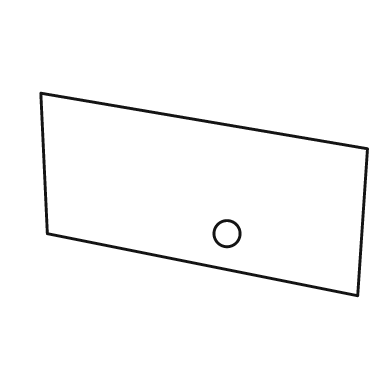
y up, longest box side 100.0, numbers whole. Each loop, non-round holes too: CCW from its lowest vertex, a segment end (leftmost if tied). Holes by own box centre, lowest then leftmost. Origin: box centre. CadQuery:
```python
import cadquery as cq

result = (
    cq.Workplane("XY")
    .moveTo(47.0, -31.0)
    .lineTo(50.0, 14.0)
    .lineTo(-50.0, 31.0)
    .lineTo(-48.0, -12.0)
    .close()
    .moveTo(7.0, -12.0)
    .circle(4.0)
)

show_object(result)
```